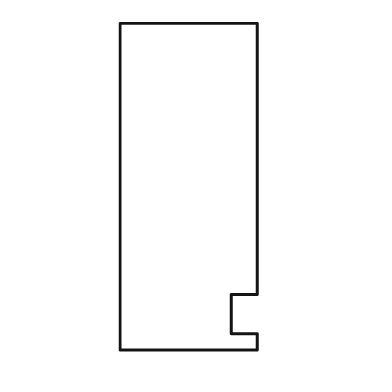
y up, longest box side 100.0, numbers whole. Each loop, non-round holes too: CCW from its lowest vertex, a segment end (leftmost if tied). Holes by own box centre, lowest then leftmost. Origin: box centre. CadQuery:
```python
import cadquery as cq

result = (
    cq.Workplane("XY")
    .moveTo(-21.0, -50.0)
    .lineTo(21.0, -50.0)
    .lineTo(21.0, -45.0)
    .lineTo(13.0, -45.0)
    .lineTo(13.0, -33.0)
    .lineTo(21.0, -33.0)
    .lineTo(21.0, 50.0)
    .lineTo(-21.0, 50.0)
    .close()
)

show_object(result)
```